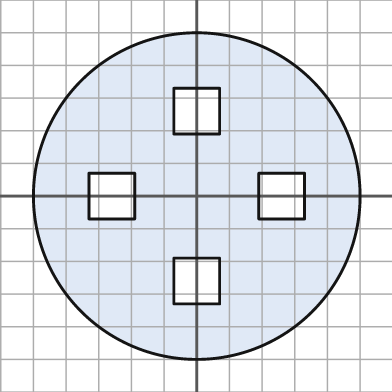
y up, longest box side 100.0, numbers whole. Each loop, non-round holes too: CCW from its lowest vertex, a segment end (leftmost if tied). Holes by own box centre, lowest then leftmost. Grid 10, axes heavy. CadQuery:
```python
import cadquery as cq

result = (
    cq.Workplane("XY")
    .moveTo(0.0, 0.0)
    .circle(50.0)
    .moveTo(-7.0, -33.0)
    .lineTo(7.0, -33.0)
    .lineTo(7.0, -19.0)
    .lineTo(-7.0, -19.0)
    .close()
    .moveTo(-33.0, -7.0)
    .lineTo(-19.0, -7.0)
    .lineTo(-19.0, 7.0)
    .lineTo(-33.0, 7.0)
    .close()
    .moveTo(19.0, -7.0)
    .lineTo(33.0, -7.0)
    .lineTo(33.0, 7.0)
    .lineTo(19.0, 7.0)
    .close()
    .moveTo(-7.0, 19.0)
    .lineTo(7.0, 19.0)
    .lineTo(7.0, 33.0)
    .lineTo(-7.0, 33.0)
    .close()
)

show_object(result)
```